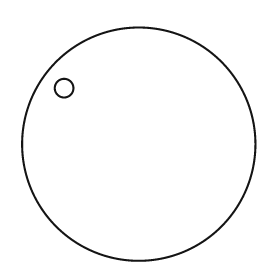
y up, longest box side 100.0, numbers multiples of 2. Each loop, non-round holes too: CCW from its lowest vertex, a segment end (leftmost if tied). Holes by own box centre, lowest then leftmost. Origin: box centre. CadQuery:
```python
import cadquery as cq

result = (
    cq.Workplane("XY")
    .moveTo(0.0, 0.0)
    .circle(50.0)
    .moveTo(-32.0, 24.0)
    .circle(4.0)
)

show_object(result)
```